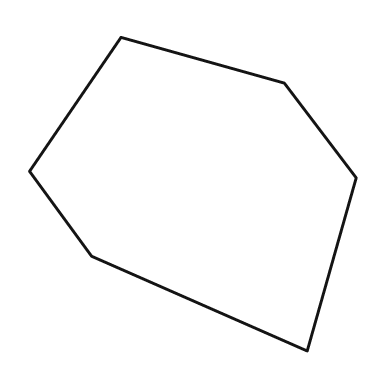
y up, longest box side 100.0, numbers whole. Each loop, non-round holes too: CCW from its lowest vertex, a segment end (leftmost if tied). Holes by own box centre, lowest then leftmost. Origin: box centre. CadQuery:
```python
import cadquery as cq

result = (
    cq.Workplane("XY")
    .moveTo(35.0, -48.0)
    .lineTo(50.0, 5.0)
    .lineTo(28.0, 34.0)
    .lineTo(-22.0, 48.0)
    .lineTo(-50.0, 7.0)
    .lineTo(-31.0, -19.0)
    .close()
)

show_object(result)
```